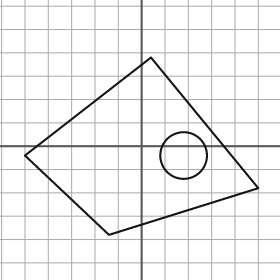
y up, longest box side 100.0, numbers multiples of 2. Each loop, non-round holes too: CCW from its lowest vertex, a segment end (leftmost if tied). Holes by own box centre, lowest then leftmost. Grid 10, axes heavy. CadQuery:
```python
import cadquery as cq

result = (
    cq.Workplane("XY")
    .moveTo(-14.0, -38.0)
    .lineTo(50.0, -18.0)
    .lineTo(4.0, 38.0)
    .lineTo(-50.0, -4.0)
    .close()
    .moveTo(18.0, -4.0)
    .circle(10.0)
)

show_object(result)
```